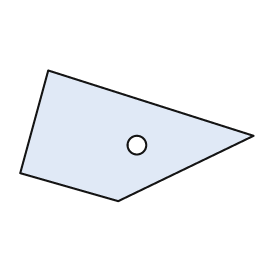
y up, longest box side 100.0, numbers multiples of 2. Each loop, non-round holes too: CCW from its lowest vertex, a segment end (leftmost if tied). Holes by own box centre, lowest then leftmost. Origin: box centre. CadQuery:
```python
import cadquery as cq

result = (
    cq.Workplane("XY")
    .moveTo(-8.0, -28.0)
    .lineTo(50.0, 0.0)
    .lineTo(-38.0, 28.0)
    .lineTo(-50.0, -16.0)
    .close()
    .moveTo(0.0, -4.0)
    .circle(4.0)
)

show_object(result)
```